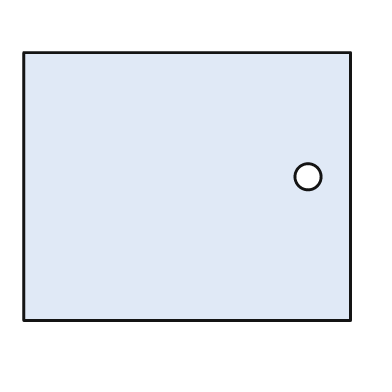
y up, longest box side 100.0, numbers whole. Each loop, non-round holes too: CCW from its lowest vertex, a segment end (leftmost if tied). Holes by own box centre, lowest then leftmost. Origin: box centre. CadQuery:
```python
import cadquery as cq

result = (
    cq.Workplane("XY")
    .moveTo(-50.0, -41.0)
    .lineTo(50.0, -41.0)
    .lineTo(50.0, 41.0)
    .lineTo(-50.0, 41.0)
    .close()
    .moveTo(37.0, 3.0)
    .circle(4.0)
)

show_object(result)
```